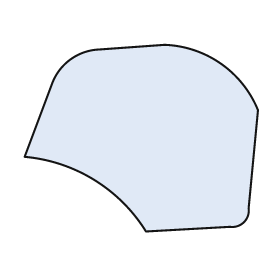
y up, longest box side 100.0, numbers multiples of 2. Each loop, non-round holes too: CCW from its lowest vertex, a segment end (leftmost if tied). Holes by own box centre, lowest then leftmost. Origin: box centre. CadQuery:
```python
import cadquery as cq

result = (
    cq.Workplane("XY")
    .moveTo(2.0, -40.0)
    .lineTo(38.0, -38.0)
    .threePointArc((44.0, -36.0), (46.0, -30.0))
    .lineTo(50.0, 12.0)
    .threePointArc((34.0, 32.0), (10.0, 40.0))
    .lineTo(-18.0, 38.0)
    .threePointArc((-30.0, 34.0), (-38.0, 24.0))
    .lineTo(-50.0, -8.0)
    .threePointArc((-20.0, -18.0), (2.0, -40.0))
    .close()
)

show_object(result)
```